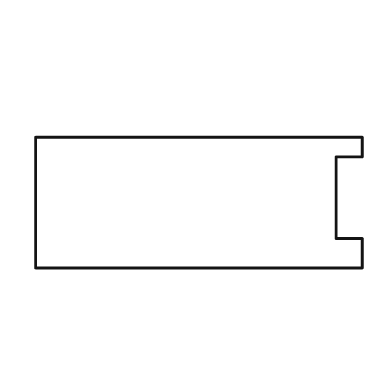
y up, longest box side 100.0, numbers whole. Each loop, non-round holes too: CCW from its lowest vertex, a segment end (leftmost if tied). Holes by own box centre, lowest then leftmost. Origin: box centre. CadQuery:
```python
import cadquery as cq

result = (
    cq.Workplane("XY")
    .moveTo(-50.0, -20.0)
    .lineTo(50.0, -20.0)
    .lineTo(50.0, -11.0)
    .lineTo(42.0, -11.0)
    .lineTo(42.0, 14.0)
    .lineTo(50.0, 14.0)
    .lineTo(50.0, 20.0)
    .lineTo(-50.0, 20.0)
    .close()
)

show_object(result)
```